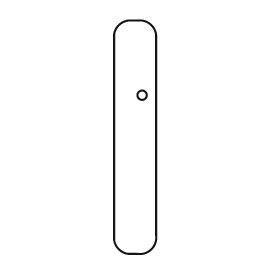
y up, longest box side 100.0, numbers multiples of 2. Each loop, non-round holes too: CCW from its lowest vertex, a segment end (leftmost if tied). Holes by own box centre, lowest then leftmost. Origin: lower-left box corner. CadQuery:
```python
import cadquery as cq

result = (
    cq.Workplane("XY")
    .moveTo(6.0, 0.0)
    .lineTo(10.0, 0.0)
    .threePointArc((16.0, 2.0), (18.0, 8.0))
    .lineTo(18.0, 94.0)
    .threePointArc((16.0, 98.0), (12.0, 100.0))
    .lineTo(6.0, 100.0)
    .threePointArc((2.0, 98.0), (0.0, 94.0))
    .lineTo(0.0, 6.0)
    .threePointArc((2.0, 2.0), (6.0, 0.0))
    .close()
    .moveTo(12.0, 68.0)
    .circle(2.0)
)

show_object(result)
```